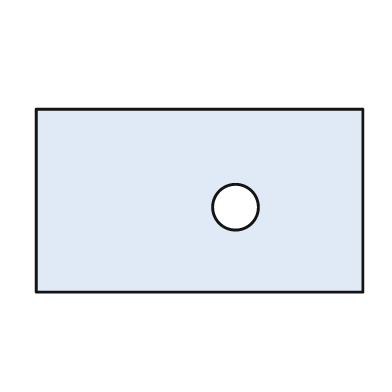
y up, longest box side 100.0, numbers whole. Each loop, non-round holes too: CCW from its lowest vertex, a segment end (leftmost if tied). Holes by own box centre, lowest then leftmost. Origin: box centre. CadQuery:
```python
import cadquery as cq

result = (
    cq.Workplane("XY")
    .moveTo(-50.0, -28.0)
    .lineTo(50.0, -28.0)
    .lineTo(50.0, 28.0)
    .lineTo(-50.0, 28.0)
    .close()
    .moveTo(11.0, -2.0)
    .circle(7.0)
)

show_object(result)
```